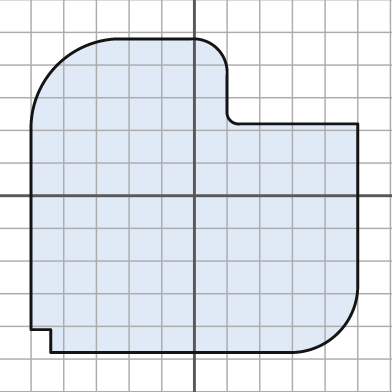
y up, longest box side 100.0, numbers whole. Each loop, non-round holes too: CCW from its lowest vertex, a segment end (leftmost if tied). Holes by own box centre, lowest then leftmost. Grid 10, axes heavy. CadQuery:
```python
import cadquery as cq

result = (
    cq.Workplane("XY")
    .moveTo(-44.0, -48.0)
    .lineTo(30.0, -48.0)
    .threePointArc((44.0, -42.0), (50.0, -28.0))
    .lineTo(50.0, 22.0)
    .lineTo(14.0, 22.0)
    .threePointArc((11.0, 23.0), (10.0, 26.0))
    .lineTo(10.0, 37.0)
    .threePointArc((7.0, 45.0), (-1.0, 48.0))
    .lineTo(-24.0, 48.0)
    .threePointArc((-42.0, 40.0), (-50.0, 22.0))
    .lineTo(-50.0, -41.0)
    .lineTo(-44.0, -41.0)
    .close()
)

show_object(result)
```